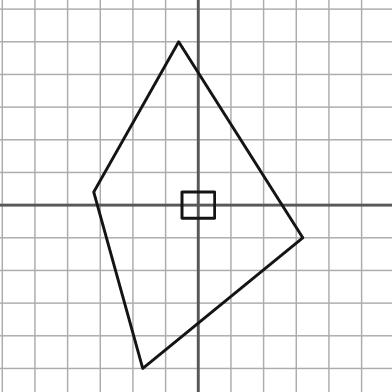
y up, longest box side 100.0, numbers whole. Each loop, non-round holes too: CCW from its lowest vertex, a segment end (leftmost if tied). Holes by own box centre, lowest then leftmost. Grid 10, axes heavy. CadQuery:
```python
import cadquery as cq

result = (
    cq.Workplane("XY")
    .moveTo(-17.0, -50.0)
    .lineTo(32.0, -10.0)
    .lineTo(-6.0, 50.0)
    .lineTo(-32.0, 4.0)
    .close()
    .moveTo(-5.0, -4.0)
    .lineTo(5.0, -4.0)
    .lineTo(5.0, 4.0)
    .lineTo(-5.0, 4.0)
    .close()
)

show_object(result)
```